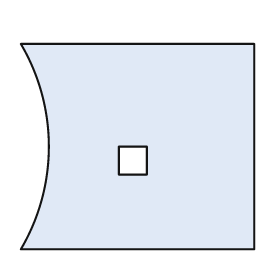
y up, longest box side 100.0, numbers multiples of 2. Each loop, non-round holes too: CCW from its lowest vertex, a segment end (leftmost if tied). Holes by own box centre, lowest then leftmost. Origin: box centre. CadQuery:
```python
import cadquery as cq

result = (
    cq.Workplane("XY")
    .moveTo(-50.0, -44.0)
    .lineTo(50.0, -44.0)
    .lineTo(50.0, 44.0)
    .lineTo(-50.0, 44.0)
    .threePointArc((-38.0, 0.0), (-50.0, -44.0))
    .close()
    .moveTo(-8.0, -12.0)
    .lineTo(4.0, -12.0)
    .lineTo(4.0, 0.0)
    .lineTo(-8.0, 0.0)
    .close()
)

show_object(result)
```